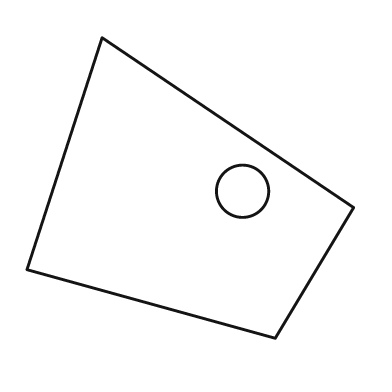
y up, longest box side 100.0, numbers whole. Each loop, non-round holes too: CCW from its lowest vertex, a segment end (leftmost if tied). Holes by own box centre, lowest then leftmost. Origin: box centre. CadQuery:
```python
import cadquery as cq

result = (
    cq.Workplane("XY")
    .moveTo(26.0, -46.0)
    .lineTo(50.0, -6.0)
    .lineTo(-27.0, 46.0)
    .lineTo(-50.0, -25.0)
    .close()
    .moveTo(16.0, -1.0)
    .circle(8.0)
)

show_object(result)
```